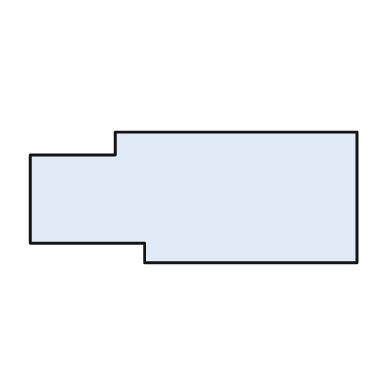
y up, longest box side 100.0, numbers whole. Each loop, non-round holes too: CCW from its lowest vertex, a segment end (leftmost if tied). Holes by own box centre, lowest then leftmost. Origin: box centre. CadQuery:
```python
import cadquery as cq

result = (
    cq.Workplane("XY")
    .moveTo(-15.0, -20.0)
    .lineTo(50.0, -20.0)
    .lineTo(50.0, 20.0)
    .lineTo(-24.0, 20.0)
    .lineTo(-24.0, 13.0)
    .lineTo(-50.0, 13.0)
    .lineTo(-50.0, -14.0)
    .lineTo(-15.0, -14.0)
    .close()
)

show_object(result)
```